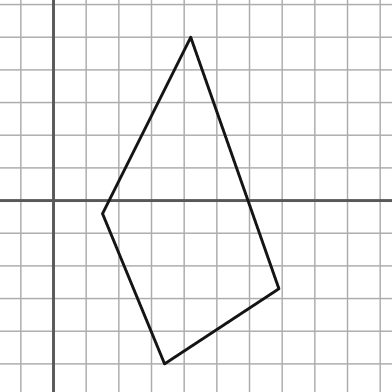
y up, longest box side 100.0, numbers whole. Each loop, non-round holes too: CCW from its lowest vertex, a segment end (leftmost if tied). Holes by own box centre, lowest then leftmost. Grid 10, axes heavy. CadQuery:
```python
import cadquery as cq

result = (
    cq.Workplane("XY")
    .moveTo(34.0, -50.0)
    .lineTo(69.0, -27.0)
    .lineTo(42.0, 50.0)
    .lineTo(15.0, -4.0)
    .close()
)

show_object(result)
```